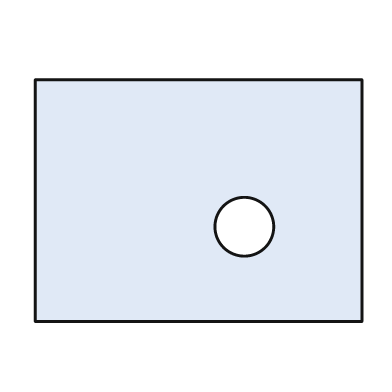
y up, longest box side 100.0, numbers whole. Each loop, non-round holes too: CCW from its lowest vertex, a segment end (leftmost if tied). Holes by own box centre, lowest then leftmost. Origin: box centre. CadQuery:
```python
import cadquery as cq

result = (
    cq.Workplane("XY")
    .moveTo(-50.0, -37.0)
    .lineTo(50.0, -37.0)
    .lineTo(50.0, 37.0)
    .lineTo(-50.0, 37.0)
    .close()
    .moveTo(14.0, -8.0)
    .circle(9.0)
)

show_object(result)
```